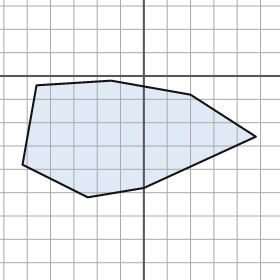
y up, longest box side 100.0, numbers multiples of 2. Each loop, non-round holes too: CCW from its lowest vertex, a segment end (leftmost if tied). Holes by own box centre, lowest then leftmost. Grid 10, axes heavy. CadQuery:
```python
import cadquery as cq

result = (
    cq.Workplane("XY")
    .moveTo(-24.0, -52.0)
    .lineTo(0.0, -48.0)
    .lineTo(48.0, -26.0)
    .lineTo(20.0, -8.0)
    .lineTo(-14.0, -2.0)
    .lineTo(-46.0, -4.0)
    .lineTo(-52.0, -38.0)
    .close()
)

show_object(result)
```